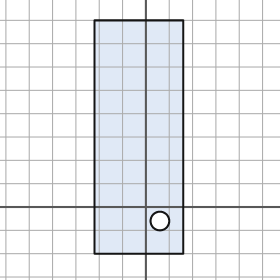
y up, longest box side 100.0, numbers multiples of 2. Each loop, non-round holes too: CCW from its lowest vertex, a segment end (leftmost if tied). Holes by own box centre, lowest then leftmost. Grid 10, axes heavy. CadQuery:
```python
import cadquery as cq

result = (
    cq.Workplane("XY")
    .moveTo(-22.0, -20.0)
    .lineTo(16.0, -20.0)
    .lineTo(16.0, 80.0)
    .lineTo(-22.0, 80.0)
    .close()
    .moveTo(6.0, -6.0)
    .circle(4.0)
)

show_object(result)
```